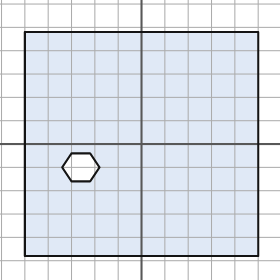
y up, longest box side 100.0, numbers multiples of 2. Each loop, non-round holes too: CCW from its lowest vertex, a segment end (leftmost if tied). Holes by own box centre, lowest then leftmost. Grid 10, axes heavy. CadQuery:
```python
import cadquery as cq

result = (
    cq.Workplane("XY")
    .moveTo(-50.0, -48.0)
    .lineTo(50.0, -48.0)
    .lineTo(50.0, 48.0)
    .lineTo(-50.0, 48.0)
    .close()
    .moveTo(-30.0, -16.0)
    .lineTo(-22.0, -16.0)
    .lineTo(-18.0, -10.0)
    .lineTo(-22.0, -4.0)
    .lineTo(-30.0, -4.0)
    .lineTo(-34.0, -10.0)
    .close()
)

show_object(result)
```